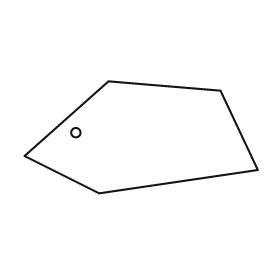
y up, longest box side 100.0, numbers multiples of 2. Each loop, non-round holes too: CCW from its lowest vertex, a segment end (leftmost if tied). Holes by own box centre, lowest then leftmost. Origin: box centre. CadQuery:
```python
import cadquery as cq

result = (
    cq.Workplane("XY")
    .moveTo(-18.0, -24.0)
    .lineTo(50.0, -14.0)
    .lineTo(34.0, 20.0)
    .lineTo(-14.0, 24.0)
    .lineTo(-50.0, -8.0)
    .close()
    .moveTo(-28.0, 2.0)
    .circle(2.0)
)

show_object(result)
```